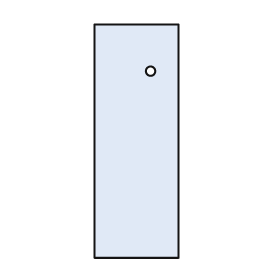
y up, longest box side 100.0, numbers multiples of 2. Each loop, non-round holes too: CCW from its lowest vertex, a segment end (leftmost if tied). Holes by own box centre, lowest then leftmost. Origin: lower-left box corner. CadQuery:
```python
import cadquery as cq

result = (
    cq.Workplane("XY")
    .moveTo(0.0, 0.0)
    .lineTo(36.0, 0.0)
    .lineTo(36.0, 100.0)
    .lineTo(0.0, 100.0)
    .close()
    .moveTo(24.0, 80.0)
    .circle(2.0)
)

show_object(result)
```